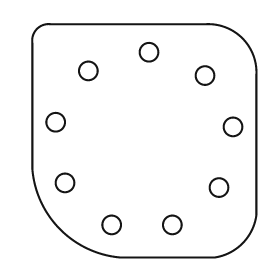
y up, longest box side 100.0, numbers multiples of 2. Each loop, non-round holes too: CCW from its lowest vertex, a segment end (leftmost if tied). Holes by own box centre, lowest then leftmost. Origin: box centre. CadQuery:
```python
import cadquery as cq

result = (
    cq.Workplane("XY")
    .moveTo(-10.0, -50.0)
    .lineTo(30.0, -50.0)
    .threePointArc((42.0, -44.0), (48.0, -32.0))
    .lineTo(48.0, 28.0)
    .threePointArc((42.0, 44.0), (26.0, 50.0))
    .lineTo(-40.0, 50.0)
    .threePointArc((-46.0, 48.0), (-48.0, 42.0))
    .lineTo(-48.0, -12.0)
    .threePointArc((-36.0, -38.0), (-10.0, -50.0))
    .close()
    .moveTo(-14.0, -36.0)
    .circle(4.0)
    .moveTo(12.0, -36.0)
    .circle(4.0)
    .moveTo(32.0, -20.0)
    .circle(4.0)
    .moveTo(-34.0, -18.0)
    .circle(4.0)
    .moveTo(38.0, 6.0)
    .circle(4.0)
    .moveTo(-38.0, 8.0)
    .circle(4.0)
    .moveTo(26.0, 28.0)
    .circle(4.0)
    .moveTo(-24.0, 30.0)
    .circle(4.0)
    .moveTo(2.0, 38.0)
    .circle(4.0)
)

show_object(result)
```